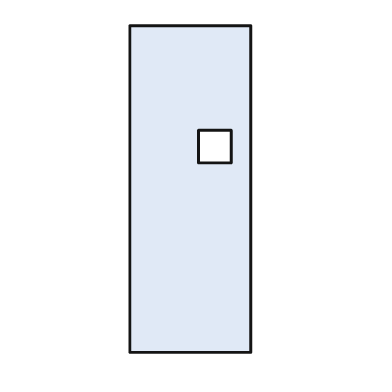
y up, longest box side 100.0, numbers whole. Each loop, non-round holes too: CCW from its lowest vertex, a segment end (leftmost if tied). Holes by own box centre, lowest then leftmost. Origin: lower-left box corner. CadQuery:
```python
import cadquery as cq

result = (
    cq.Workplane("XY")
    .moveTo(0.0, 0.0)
    .lineTo(37.0, 0.0)
    .lineTo(37.0, 100.0)
    .lineTo(0.0, 100.0)
    .close()
    .moveTo(21.0, 58.0)
    .lineTo(31.0, 58.0)
    .lineTo(31.0, 68.0)
    .lineTo(21.0, 68.0)
    .close()
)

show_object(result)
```